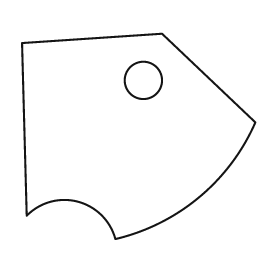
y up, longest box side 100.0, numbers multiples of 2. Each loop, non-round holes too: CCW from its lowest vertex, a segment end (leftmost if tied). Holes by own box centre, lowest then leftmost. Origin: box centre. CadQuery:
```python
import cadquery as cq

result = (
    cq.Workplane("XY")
    .moveTo(-10.0, -44.0)
    .threePointArc((26.0, -26.0), (50.0, 6.0))
    .lineTo(10.0, 44.0)
    .lineTo(-50.0, 40.0)
    .lineTo(-48.0, -34.0)
    .threePointArc((-26.0, -28.0), (-10.0, -44.0))
    .close()
    .moveTo(2.0, 24.0)
    .circle(8.0)
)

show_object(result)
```